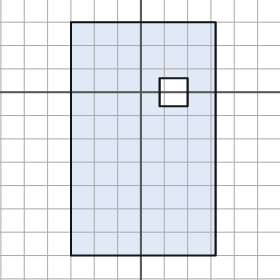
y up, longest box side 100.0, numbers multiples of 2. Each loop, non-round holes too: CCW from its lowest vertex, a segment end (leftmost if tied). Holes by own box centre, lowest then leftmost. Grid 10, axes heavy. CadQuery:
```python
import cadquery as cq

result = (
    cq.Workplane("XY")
    .moveTo(-30.0, -70.0)
    .lineTo(32.0, -70.0)
    .lineTo(32.0, 30.0)
    .lineTo(-30.0, 30.0)
    .close()
    .moveTo(8.0, -6.0)
    .lineTo(20.0, -6.0)
    .lineTo(20.0, 6.0)
    .lineTo(8.0, 6.0)
    .close()
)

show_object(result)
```